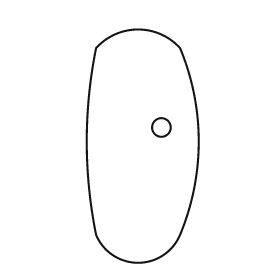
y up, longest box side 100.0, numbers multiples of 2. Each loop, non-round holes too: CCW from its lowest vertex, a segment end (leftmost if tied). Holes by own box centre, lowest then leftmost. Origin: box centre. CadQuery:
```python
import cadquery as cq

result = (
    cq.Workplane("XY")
    .moveTo(-20.0, -38.0)
    .threePointArc((-2.0, -50.0), (16.0, -38.0))
    .threePointArc((24.0, 2.0), (16.0, 42.0))
    .threePointArc((-2.0, 50.0), (-20.0, 42.0))
    .threePointArc((-24.0, 2.0), (-20.0, -38.0))
    .close()
    .moveTo(8.0, 8.0)
    .circle(4.0)
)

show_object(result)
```